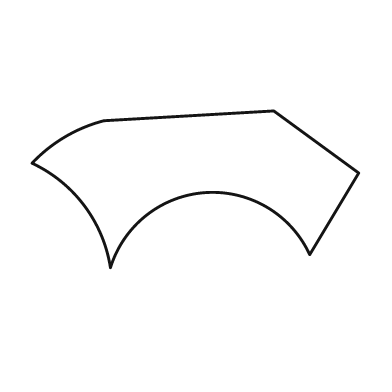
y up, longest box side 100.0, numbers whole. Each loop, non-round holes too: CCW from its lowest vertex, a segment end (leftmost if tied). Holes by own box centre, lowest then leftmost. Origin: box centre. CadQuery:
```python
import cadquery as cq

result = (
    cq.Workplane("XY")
    .moveTo(-26.0, -24.0)
    .threePointArc((3.0, -1.0), (35.0, -20.0))
    .lineTo(50.0, 5.0)
    .lineTo(24.0, 24.0)
    .lineTo(-28.0, 21.0)
    .threePointArc((-40.0, 16.0), (-50.0, 8.0))
    .threePointArc((-34.0, -5.0), (-26.0, -24.0))
    .close()
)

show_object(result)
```